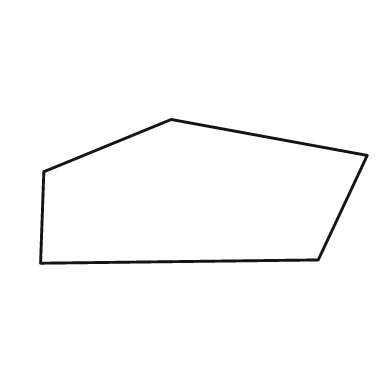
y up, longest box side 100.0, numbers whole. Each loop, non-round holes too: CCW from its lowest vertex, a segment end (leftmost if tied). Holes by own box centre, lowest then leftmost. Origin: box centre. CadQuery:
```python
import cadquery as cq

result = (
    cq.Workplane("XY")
    .moveTo(-50.0, -22.0)
    .lineTo(35.0, -21.0)
    .lineTo(50.0, 11.0)
    .lineTo(-10.0, 22.0)
    .lineTo(-49.0, 6.0)
    .close()
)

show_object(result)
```